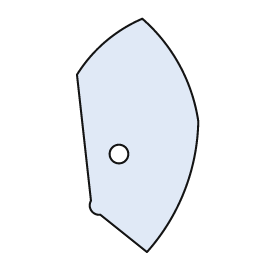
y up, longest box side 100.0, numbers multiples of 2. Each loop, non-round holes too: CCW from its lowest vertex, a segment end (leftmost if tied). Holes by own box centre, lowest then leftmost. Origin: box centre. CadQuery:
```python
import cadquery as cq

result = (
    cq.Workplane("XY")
    .moveTo(4.0, -50.0)
    .threePointArc((20.0, -24.0), (26.0, 6.0))
    .threePointArc((18.0, 30.0), (2.0, 50.0))
    .threePointArc((-14.0, 40.0), (-26.0, 26.0))
    .lineTo(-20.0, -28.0)
    .threePointArc((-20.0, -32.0), (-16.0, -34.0))
    .close()
    .moveTo(-8.0, -8.0)
    .circle(4.0)
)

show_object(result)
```